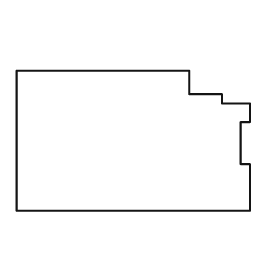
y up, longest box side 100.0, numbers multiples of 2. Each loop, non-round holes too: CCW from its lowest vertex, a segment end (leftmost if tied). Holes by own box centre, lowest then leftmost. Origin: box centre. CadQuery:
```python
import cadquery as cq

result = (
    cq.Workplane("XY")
    .moveTo(-50.0, -30.0)
    .lineTo(50.0, -30.0)
    .lineTo(50.0, -10.0)
    .lineTo(46.0, -10.0)
    .lineTo(46.0, 8.0)
    .lineTo(50.0, 8.0)
    .lineTo(50.0, 16.0)
    .lineTo(38.0, 16.0)
    .lineTo(38.0, 20.0)
    .lineTo(24.0, 20.0)
    .lineTo(24.0, 30.0)
    .lineTo(-50.0, 30.0)
    .close()
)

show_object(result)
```